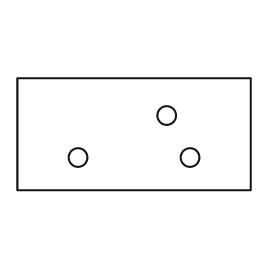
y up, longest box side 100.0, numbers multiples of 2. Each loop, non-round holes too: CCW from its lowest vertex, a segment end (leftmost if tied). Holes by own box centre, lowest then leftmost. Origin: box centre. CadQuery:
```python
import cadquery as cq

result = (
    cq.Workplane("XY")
    .moveTo(-50.0, -24.0)
    .lineTo(50.0, -24.0)
    .lineTo(50.0, 24.0)
    .lineTo(-50.0, 24.0)
    .close()
    .moveTo(-24.0, -10.0)
    .circle(4.0)
    .moveTo(24.0, -10.0)
    .circle(4.0)
    .moveTo(14.0, 8.0)
    .circle(4.0)
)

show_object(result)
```